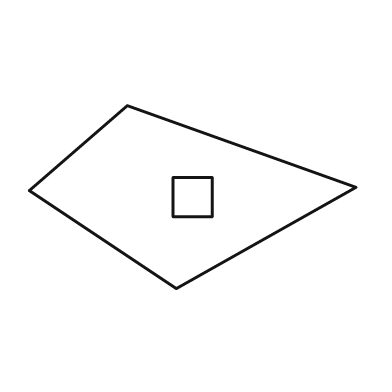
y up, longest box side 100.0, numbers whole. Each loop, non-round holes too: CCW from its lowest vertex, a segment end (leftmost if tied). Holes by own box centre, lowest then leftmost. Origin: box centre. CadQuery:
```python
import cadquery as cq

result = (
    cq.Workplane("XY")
    .moveTo(-5.0, -28.0)
    .lineTo(50.0, 3.0)
    .lineTo(-20.0, 28.0)
    .lineTo(-50.0, 2.0)
    .close()
    .moveTo(-6.0, -6.0)
    .lineTo(6.0, -6.0)
    .lineTo(6.0, 6.0)
    .lineTo(-6.0, 6.0)
    .close()
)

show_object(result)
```